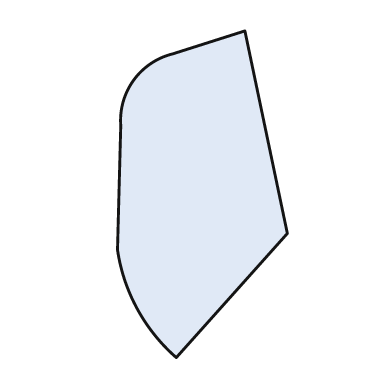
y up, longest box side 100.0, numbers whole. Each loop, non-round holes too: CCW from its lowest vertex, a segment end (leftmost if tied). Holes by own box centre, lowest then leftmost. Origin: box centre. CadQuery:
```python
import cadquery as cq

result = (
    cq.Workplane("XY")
    .moveTo(-8.0, -50.0)
    .lineTo(26.0, -12.0)
    .lineTo(13.0, 50.0)
    .lineTo(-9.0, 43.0)
    .threePointArc((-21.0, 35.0), (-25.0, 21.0))
    .lineTo(-26.0, -17.0)
    .threePointArc((-20.0, -35.0), (-8.0, -50.0))
    .close()
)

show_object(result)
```